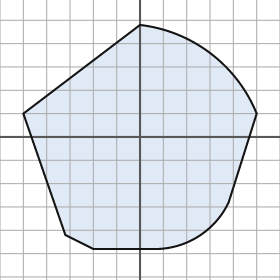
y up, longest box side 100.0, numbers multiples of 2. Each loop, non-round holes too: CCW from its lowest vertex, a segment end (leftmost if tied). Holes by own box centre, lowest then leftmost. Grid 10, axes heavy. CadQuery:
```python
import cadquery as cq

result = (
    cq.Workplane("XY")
    .moveTo(-20.0, -48.0)
    .lineTo(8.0, -48.0)
    .threePointArc((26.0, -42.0), (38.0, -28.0))
    .lineTo(50.0, 10.0)
    .threePointArc((30.0, 36.0), (0.0, 48.0))
    .lineTo(-50.0, 10.0)
    .lineTo(-32.0, -42.0)
    .close()
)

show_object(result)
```